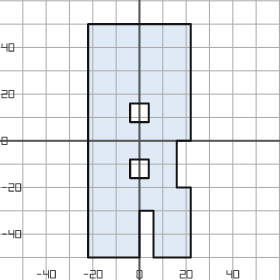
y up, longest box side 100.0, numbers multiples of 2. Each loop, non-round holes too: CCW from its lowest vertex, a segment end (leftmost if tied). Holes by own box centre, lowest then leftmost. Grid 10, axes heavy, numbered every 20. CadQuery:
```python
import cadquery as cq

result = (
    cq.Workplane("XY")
    .moveTo(-22.0, -50.0)
    .lineTo(0.0, -50.0)
    .lineTo(0.0, -30.0)
    .lineTo(6.0, -30.0)
    .lineTo(6.0, -50.0)
    .lineTo(22.0, -50.0)
    .lineTo(22.0, -20.0)
    .lineTo(16.0, -20.0)
    .lineTo(16.0, 0.0)
    .lineTo(22.0, 0.0)
    .lineTo(22.0, 50.0)
    .lineTo(-22.0, 50.0)
    .close()
    .moveTo(-4.0, -16.0)
    .lineTo(4.0, -16.0)
    .lineTo(4.0, -8.0)
    .lineTo(-4.0, -8.0)
    .close()
    .moveTo(-4.0, 8.0)
    .lineTo(4.0, 8.0)
    .lineTo(4.0, 16.0)
    .lineTo(-4.0, 16.0)
    .close()
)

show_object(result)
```